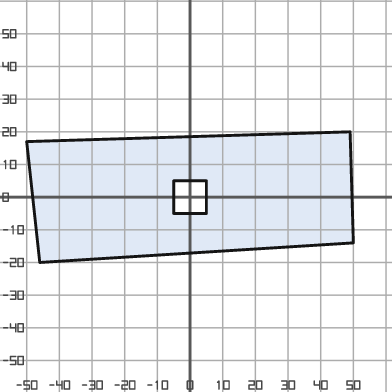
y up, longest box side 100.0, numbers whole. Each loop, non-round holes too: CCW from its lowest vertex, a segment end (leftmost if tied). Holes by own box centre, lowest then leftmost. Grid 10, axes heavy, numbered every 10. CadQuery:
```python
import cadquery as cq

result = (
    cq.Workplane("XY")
    .moveTo(-46.0, -20.0)
    .lineTo(50.0, -14.0)
    .lineTo(49.0, 20.0)
    .lineTo(-50.0, 17.0)
    .close()
    .moveTo(-5.0, -5.0)
    .lineTo(5.0, -5.0)
    .lineTo(5.0, 5.0)
    .lineTo(-5.0, 5.0)
    .close()
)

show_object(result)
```